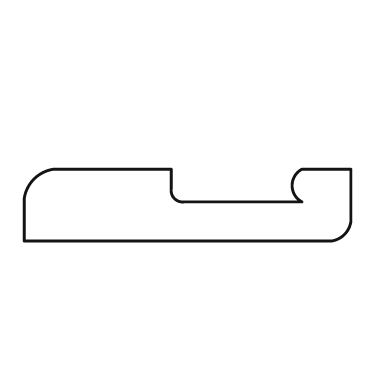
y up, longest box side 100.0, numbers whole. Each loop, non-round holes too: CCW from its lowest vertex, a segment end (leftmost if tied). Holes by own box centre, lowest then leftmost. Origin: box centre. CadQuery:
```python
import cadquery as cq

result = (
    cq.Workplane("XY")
    .moveTo(-50.0, -11.0)
    .lineTo(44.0, -11.0)
    .threePointArc((48.0, -9.0), (50.0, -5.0))
    .lineTo(50.0, 11.0)
    .lineTo(35.0, 11.0)
    .threePointArc((32.0, 6.0), (35.0, 1.0))
    .lineTo(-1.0, 1.0)
    .threePointArc((-4.0, 2.0), (-5.0, 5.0))
    .lineTo(-5.0, 11.0)
    .lineTo(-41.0, 11.0)
    .threePointArc((-47.0, 8.0), (-50.0, 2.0))
    .close()
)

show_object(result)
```